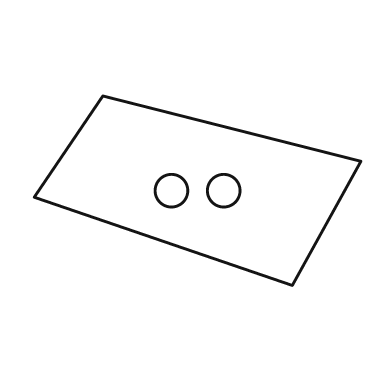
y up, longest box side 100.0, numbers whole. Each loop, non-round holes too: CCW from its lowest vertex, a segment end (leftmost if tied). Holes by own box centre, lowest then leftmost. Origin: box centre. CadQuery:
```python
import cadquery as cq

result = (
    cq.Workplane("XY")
    .moveTo(29.0, -29.0)
    .lineTo(50.0, 9.0)
    .lineTo(-29.0, 29.0)
    .lineTo(-50.0, -2.0)
    .close()
    .moveTo(-8.0, 0.0)
    .circle(5.0)
    .moveTo(8.0, 0.0)
    .circle(5.0)
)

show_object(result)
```